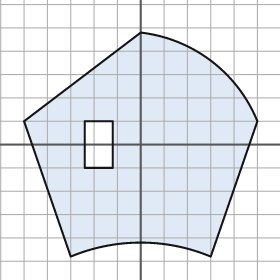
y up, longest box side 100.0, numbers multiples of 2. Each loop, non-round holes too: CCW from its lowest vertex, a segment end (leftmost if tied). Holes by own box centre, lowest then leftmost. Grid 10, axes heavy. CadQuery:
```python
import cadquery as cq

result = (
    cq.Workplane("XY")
    .moveTo(-30.0, -48.0)
    .threePointArc((0.0, -42.0), (30.0, -48.0))
    .lineTo(50.0, 10.0)
    .threePointArc((30.0, 36.0), (0.0, 48.0))
    .lineTo(-50.0, 10.0)
    .close()
    .moveTo(-24.0, -10.0)
    .lineTo(-12.0, -10.0)
    .lineTo(-12.0, 10.0)
    .lineTo(-24.0, 10.0)
    .close()
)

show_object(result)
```